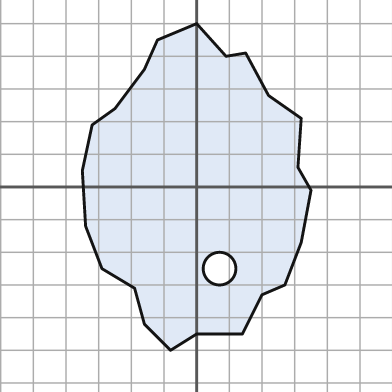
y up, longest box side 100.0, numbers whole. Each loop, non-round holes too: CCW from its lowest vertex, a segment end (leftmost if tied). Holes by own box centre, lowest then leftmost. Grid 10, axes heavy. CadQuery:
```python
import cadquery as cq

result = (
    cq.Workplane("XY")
    .moveTo(-8.0, -50.0)
    .lineTo(0.0, -45.0)
    .lineTo(14.0, -45.0)
    .lineTo(20.0, -33.0)
    .lineTo(27.0, -30.0)
    .lineTo(32.0, -17.0)
    .lineTo(35.0, -1.0)
    .lineTo(31.0, 6.0)
    .lineTo(32.0, 21.0)
    .lineTo(22.0, 28.0)
    .lineTo(15.0, 41.0)
    .lineTo(9.0, 40.0)
    .lineTo(0.0, 50.0)
    .lineTo(-12.0, 45.0)
    .lineTo(-16.0, 36.0)
    .lineTo(-25.0, 24.0)
    .lineTo(-32.0, 19.0)
    .lineTo(-35.0, 5.0)
    .lineTo(-34.0, -12.0)
    .lineTo(-29.0, -25.0)
    .lineTo(-19.0, -31.0)
    .lineTo(-16.0, -42.0)
    .close()
    .moveTo(7.0, -25.0)
    .circle(5.0)
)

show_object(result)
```